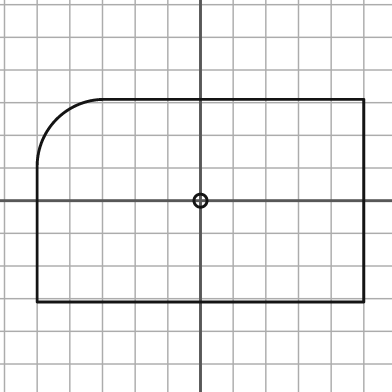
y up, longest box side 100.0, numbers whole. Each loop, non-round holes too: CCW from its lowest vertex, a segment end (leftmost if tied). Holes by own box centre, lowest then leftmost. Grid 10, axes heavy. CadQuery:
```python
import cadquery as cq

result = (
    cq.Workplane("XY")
    .moveTo(-50.0, -31.0)
    .lineTo(50.0, -31.0)
    .lineTo(50.0, 31.0)
    .lineTo(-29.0, 31.0)
    .threePointArc((-44.0, 25.0), (-50.0, 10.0))
    .close()
    .moveTo(0.0, 0.0)
    .circle(2.0)
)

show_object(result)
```